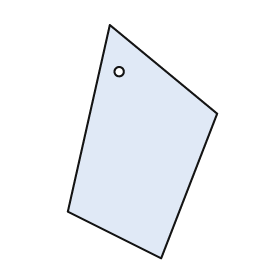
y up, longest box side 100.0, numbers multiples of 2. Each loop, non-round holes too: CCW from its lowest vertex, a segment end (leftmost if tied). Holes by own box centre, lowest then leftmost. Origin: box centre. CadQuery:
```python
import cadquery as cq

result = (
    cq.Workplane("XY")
    .moveTo(8.0, -50.0)
    .lineTo(32.0, 12.0)
    .lineTo(-14.0, 50.0)
    .lineTo(-32.0, -30.0)
    .close()
    .moveTo(-10.0, 30.0)
    .circle(2.0)
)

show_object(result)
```